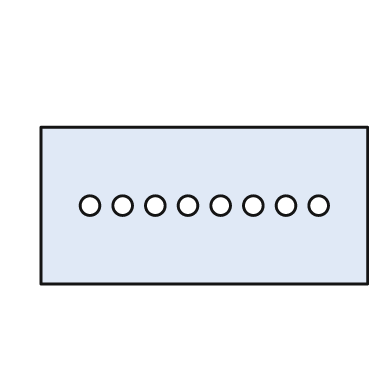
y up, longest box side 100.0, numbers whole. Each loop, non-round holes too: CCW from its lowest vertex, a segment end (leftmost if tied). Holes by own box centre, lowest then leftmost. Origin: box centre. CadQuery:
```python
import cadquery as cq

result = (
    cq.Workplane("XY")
    .moveTo(-50.0, -24.0)
    .lineTo(50.0, -24.0)
    .lineTo(50.0, 24.0)
    .lineTo(-50.0, 24.0)
    .close()
    .moveTo(-35.0, 0.0)
    .circle(3.0)
    .moveTo(-25.0, 0.0)
    .circle(3.0)
    .moveTo(-15.0, 0.0)
    .circle(3.0)
    .moveTo(-5.0, 0.0)
    .circle(3.0)
    .moveTo(5.0, 0.0)
    .circle(3.0)
    .moveTo(15.0, 0.0)
    .circle(3.0)
    .moveTo(25.0, 0.0)
    .circle(3.0)
    .moveTo(35.0, 0.0)
    .circle(3.0)
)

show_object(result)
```